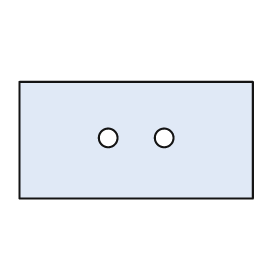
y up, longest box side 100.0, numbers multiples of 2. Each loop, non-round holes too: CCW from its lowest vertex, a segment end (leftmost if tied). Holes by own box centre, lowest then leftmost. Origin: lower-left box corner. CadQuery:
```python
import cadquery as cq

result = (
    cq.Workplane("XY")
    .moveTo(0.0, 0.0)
    .lineTo(100.0, 0.0)
    .lineTo(100.0, 50.0)
    .lineTo(0.0, 50.0)
    .close()
    .moveTo(38.0, 26.0)
    .circle(4.0)
    .moveTo(62.0, 26.0)
    .circle(4.0)
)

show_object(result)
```